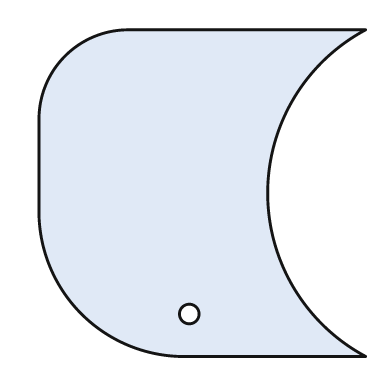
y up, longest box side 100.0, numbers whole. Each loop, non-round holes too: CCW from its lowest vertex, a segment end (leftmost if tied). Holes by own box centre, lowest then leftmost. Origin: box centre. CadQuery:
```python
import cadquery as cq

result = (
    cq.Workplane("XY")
    .moveTo(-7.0, -50.0)
    .lineTo(50.0, -50.0)
    .threePointArc((20.0, 0.0), (50.0, 50.0))
    .lineTo(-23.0, 50.0)
    .threePointArc((-42.0, 42.0), (-50.0, 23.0))
    .lineTo(-50.0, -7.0)
    .threePointArc((-37.0, -37.0), (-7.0, -50.0))
    .close()
    .moveTo(-4.0, -37.0)
    .circle(3.0)
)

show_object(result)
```